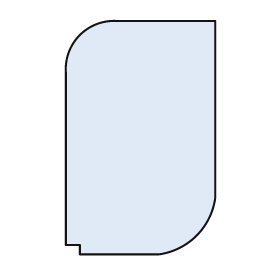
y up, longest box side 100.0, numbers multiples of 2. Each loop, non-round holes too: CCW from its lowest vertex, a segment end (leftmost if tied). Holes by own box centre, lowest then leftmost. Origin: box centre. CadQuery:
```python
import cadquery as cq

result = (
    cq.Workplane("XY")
    .moveTo(-26.0, -50.0)
    .lineTo(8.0, -50.0)
    .threePointArc((24.0, -42.0), (32.0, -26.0))
    .lineTo(32.0, 50.0)
    .lineTo(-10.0, 50.0)
    .threePointArc((-26.0, 44.0), (-32.0, 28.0))
    .lineTo(-32.0, -46.0)
    .lineTo(-26.0, -46.0)
    .close()
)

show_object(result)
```